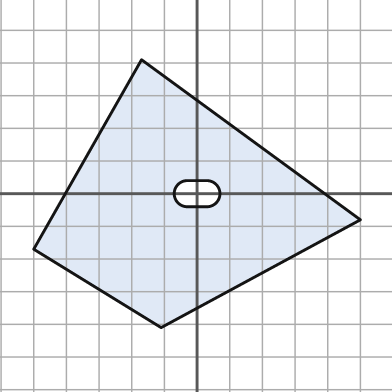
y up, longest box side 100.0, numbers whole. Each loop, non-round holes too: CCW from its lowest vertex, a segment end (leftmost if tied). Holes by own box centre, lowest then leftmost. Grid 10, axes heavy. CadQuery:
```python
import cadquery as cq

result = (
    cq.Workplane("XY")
    .moveTo(-11.0, -41.0)
    .lineTo(50.0, -8.0)
    .lineTo(-17.0, 41.0)
    .lineTo(-50.0, -17.0)
    .close()
    .moveTo(-3.0, -4.0)
    .lineTo(3.0, -4.0)
    .threePointArc((7.0, 0.0), (3.0, 4.0))
    .lineTo(-3.0, 4.0)
    .threePointArc((-7.0, 0.0), (-3.0, -4.0))
    .close()
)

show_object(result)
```